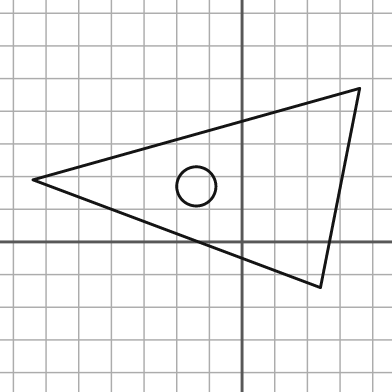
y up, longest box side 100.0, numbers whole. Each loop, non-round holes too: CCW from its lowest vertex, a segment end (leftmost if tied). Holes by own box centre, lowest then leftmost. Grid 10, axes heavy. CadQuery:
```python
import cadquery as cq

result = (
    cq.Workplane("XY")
    .moveTo(24.0, -14.0)
    .lineTo(36.0, 47.0)
    .lineTo(-64.0, 19.0)
    .close()
    .moveTo(-14.0, 17.0)
    .circle(6.0)
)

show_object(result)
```